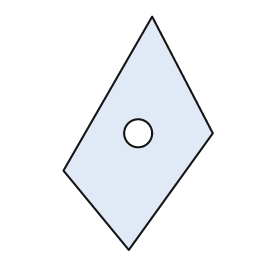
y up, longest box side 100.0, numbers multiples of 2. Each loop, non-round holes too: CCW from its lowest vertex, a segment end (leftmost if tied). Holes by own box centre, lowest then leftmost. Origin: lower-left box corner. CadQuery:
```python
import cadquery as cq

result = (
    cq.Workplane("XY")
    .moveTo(28.0, 0.0)
    .lineTo(64.0, 50.0)
    .lineTo(38.0, 100.0)
    .lineTo(0.0, 34.0)
    .close()
    .moveTo(32.0, 50.0)
    .circle(6.0)
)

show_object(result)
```